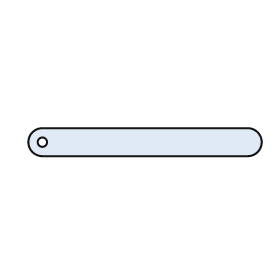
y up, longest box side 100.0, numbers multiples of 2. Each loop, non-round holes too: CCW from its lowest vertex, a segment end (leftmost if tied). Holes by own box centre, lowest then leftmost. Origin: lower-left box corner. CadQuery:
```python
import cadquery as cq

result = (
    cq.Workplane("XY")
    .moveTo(6.0, 0.0)
    .lineTo(94.0, 0.0)
    .threePointArc((100.0, 6.0), (94.0, 12.0))
    .lineTo(6.0, 12.0)
    .threePointArc((0.0, 6.0), (6.0, 0.0))
    .close()
    .moveTo(6.0, 6.0)
    .circle(2.0)
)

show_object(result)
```